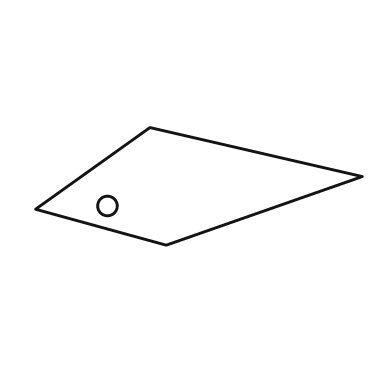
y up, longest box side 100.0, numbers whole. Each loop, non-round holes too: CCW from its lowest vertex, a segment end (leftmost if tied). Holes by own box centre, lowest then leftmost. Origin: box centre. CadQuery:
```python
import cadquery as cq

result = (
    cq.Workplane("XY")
    .moveTo(-10.0, -18.0)
    .lineTo(50.0, 3.0)
    .lineTo(-15.0, 18.0)
    .lineTo(-50.0, -7.0)
    .close()
    .moveTo(-28.0, -6.0)
    .circle(3.0)
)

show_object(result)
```